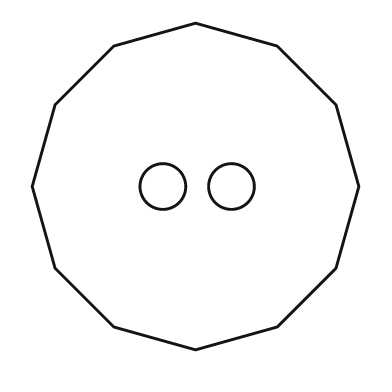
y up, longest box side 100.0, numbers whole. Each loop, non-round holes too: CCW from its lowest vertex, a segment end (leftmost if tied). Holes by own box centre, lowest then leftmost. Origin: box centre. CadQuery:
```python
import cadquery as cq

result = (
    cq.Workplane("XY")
    .moveTo(0.0, -50.0)
    .lineTo(25.0, -43.0)
    .lineTo(43.0, -25.0)
    .lineTo(50.0, 0.0)
    .lineTo(43.0, 25.0)
    .lineTo(25.0, 43.0)
    .lineTo(0.0, 50.0)
    .lineTo(-25.0, 43.0)
    .lineTo(-43.0, 25.0)
    .lineTo(-50.0, 0.0)
    .lineTo(-43.0, -25.0)
    .lineTo(-25.0, -43.0)
    .close()
    .moveTo(-10.0, 0.0)
    .circle(7.0)
    .moveTo(11.0, 0.0)
    .circle(7.0)
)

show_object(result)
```